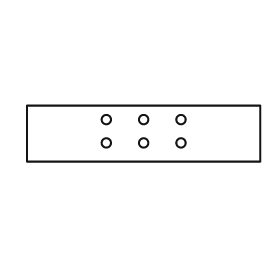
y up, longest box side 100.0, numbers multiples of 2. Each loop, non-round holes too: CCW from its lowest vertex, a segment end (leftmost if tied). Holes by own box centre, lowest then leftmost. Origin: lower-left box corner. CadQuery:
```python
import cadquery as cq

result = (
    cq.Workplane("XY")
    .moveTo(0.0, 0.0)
    .lineTo(100.0, 0.0)
    .lineTo(100.0, 24.0)
    .lineTo(0.0, 24.0)
    .close()
    .moveTo(34.0, 8.0)
    .circle(2.0)
    .moveTo(50.0, 8.0)
    .circle(2.0)
    .moveTo(66.0, 8.0)
    .circle(2.0)
    .moveTo(34.0, 18.0)
    .circle(2.0)
    .moveTo(50.0, 18.0)
    .circle(2.0)
    .moveTo(66.0, 18.0)
    .circle(2.0)
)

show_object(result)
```